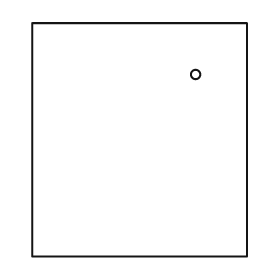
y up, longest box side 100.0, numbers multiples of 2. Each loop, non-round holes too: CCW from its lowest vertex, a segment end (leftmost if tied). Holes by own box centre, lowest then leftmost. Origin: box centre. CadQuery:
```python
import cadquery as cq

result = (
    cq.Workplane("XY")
    .moveTo(-46.0, -50.0)
    .lineTo(46.0, -50.0)
    .lineTo(46.0, 50.0)
    .lineTo(-46.0, 50.0)
    .close()
    .moveTo(24.0, 28.0)
    .circle(2.0)
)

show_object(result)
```